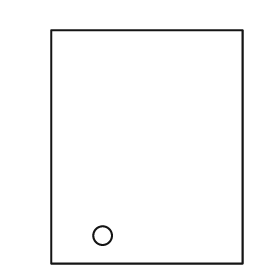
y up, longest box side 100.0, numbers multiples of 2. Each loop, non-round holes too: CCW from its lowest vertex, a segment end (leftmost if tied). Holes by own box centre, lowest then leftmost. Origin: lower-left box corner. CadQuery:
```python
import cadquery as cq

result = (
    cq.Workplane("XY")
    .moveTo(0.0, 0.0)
    .lineTo(82.0, 0.0)
    .lineTo(82.0, 100.0)
    .lineTo(0.0, 100.0)
    .close()
    .moveTo(22.0, 12.0)
    .circle(4.0)
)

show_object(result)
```